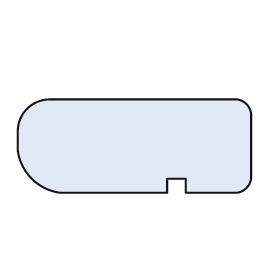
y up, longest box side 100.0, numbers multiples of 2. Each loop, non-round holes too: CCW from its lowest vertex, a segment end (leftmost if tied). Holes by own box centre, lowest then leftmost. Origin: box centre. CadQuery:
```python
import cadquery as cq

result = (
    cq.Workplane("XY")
    .moveTo(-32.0, -20.0)
    .lineTo(14.0, -20.0)
    .lineTo(14.0, -14.0)
    .lineTo(22.0, -14.0)
    .lineTo(22.0, -20.0)
    .lineTo(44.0, -20.0)
    .threePointArc((48.0, -18.0), (50.0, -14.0))
    .lineTo(50.0, 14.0)
    .threePointArc((48.0, 18.0), (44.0, 20.0))
    .lineTo(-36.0, 20.0)
    .threePointArc((-46.0, 16.0), (-50.0, 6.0))
    .lineTo(-50.0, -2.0)
    .threePointArc((-44.0, -14.0), (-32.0, -20.0))
    .close()
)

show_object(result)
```